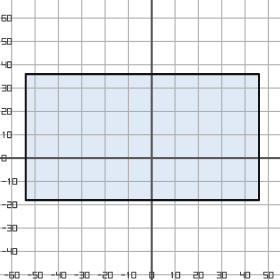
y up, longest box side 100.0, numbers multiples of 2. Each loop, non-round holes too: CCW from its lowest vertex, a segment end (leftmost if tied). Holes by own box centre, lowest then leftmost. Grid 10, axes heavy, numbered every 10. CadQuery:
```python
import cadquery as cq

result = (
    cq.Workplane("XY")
    .moveTo(-54.0, -18.0)
    .lineTo(46.0, -18.0)
    .lineTo(46.0, 36.0)
    .lineTo(-54.0, 36.0)
    .close()
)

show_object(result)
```